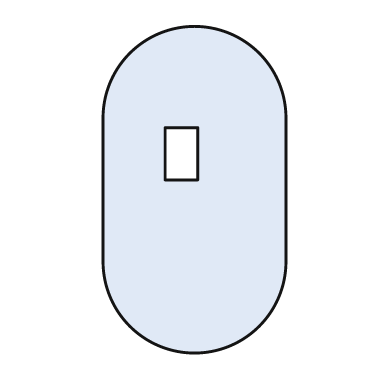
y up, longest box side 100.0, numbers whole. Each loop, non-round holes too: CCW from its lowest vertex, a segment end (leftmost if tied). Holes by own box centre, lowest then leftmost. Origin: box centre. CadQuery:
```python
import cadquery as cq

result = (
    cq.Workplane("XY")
    .moveTo(-28.0, -22.0)
    .threePointArc((0.0, -50.0), (28.0, -22.0))
    .lineTo(28.0, 22.0)
    .threePointArc((0.0, 50.0), (-28.0, 22.0))
    .close()
    .moveTo(-9.0, 3.0)
    .lineTo(1.0, 3.0)
    .lineTo(1.0, 19.0)
    .lineTo(-9.0, 19.0)
    .close()
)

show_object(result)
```